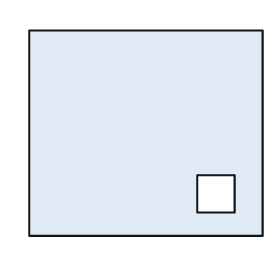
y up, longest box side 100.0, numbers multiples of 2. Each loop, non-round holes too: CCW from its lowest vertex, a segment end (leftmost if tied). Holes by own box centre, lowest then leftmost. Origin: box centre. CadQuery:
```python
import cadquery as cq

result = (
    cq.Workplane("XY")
    .moveTo(-50.0, -44.0)
    .lineTo(50.0, -44.0)
    .lineTo(50.0, 44.0)
    .lineTo(-50.0, 44.0)
    .close()
    .moveTo(22.0, -34.0)
    .lineTo(38.0, -34.0)
    .lineTo(38.0, -18.0)
    .lineTo(22.0, -18.0)
    .close()
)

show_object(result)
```